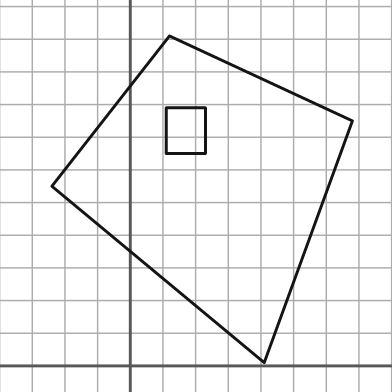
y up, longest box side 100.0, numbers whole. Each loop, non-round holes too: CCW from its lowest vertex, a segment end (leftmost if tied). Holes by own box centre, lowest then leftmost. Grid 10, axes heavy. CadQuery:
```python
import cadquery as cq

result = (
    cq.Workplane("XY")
    .moveTo(41.0, 1.0)
    .lineTo(68.0, 75.0)
    .lineTo(12.0, 101.0)
    .lineTo(-24.0, 55.0)
    .close()
    .moveTo(11.0, 65.0)
    .lineTo(23.0, 65.0)
    .lineTo(23.0, 79.0)
    .lineTo(11.0, 79.0)
    .close()
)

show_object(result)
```